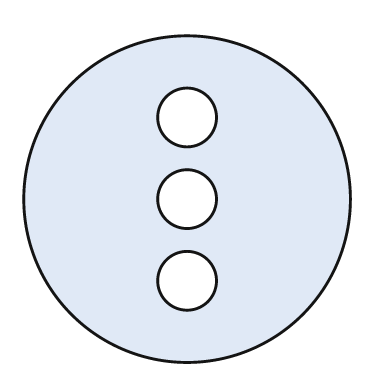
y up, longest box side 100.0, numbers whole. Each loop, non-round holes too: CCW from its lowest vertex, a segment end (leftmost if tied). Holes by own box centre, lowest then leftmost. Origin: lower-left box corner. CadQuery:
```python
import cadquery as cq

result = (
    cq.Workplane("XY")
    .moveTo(50.0, 50.0)
    .circle(50.0)
    .moveTo(50.0, 25.0)
    .circle(9.0)
    .moveTo(50.0, 50.0)
    .circle(9.0)
    .moveTo(50.0, 75.0)
    .circle(9.0)
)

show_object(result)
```